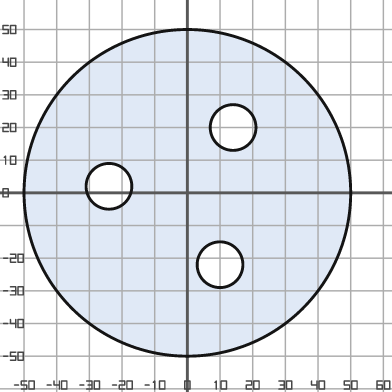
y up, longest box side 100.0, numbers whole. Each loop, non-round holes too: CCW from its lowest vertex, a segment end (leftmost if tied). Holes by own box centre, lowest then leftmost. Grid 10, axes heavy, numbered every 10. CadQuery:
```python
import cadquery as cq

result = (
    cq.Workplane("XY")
    .moveTo(0.0, 0.0)
    .circle(50.0)
    .moveTo(10.0, -22.0)
    .circle(7.0)
    .moveTo(-24.0, 2.0)
    .circle(7.0)
    .moveTo(14.0, 20.0)
    .circle(7.0)
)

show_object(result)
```